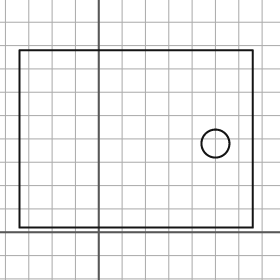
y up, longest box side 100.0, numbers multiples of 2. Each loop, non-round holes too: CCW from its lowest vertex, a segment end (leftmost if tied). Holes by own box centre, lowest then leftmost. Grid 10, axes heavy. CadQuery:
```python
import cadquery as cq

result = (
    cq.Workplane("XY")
    .moveTo(-34.0, 2.0)
    .lineTo(66.0, 2.0)
    .lineTo(66.0, 78.0)
    .lineTo(-34.0, 78.0)
    .close()
    .moveTo(50.0, 38.0)
    .circle(6.0)
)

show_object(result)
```